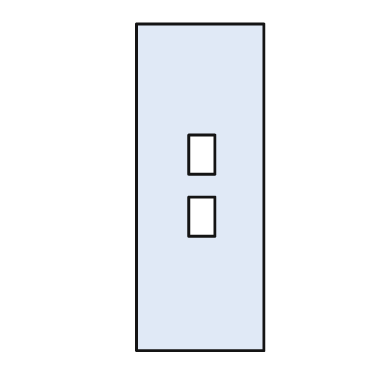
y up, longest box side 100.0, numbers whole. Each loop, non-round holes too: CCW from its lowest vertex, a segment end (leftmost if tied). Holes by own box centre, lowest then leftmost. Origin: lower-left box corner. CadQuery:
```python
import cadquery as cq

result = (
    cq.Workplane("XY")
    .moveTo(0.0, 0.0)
    .lineTo(39.0, 0.0)
    .lineTo(39.0, 100.0)
    .lineTo(0.0, 100.0)
    .close()
    .moveTo(16.0, 35.0)
    .lineTo(24.0, 35.0)
    .lineTo(24.0, 47.0)
    .lineTo(16.0, 47.0)
    .close()
    .moveTo(16.0, 54.0)
    .lineTo(24.0, 54.0)
    .lineTo(24.0, 66.0)
    .lineTo(16.0, 66.0)
    .close()
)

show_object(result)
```